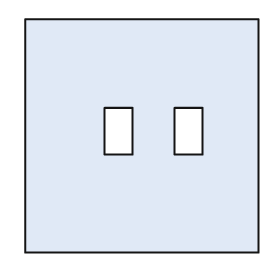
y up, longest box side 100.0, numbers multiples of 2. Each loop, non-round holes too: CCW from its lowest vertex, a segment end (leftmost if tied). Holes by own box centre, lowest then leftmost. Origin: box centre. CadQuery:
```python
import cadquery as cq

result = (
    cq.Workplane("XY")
    .moveTo(-50.0, -50.0)
    .lineTo(50.0, -50.0)
    .lineTo(50.0, 50.0)
    .lineTo(-50.0, 50.0)
    .close()
    .moveTo(-16.0, -8.0)
    .lineTo(-4.0, -8.0)
    .lineTo(-4.0, 12.0)
    .lineTo(-16.0, 12.0)
    .close()
    .moveTo(14.0, -8.0)
    .lineTo(26.0, -8.0)
    .lineTo(26.0, 12.0)
    .lineTo(14.0, 12.0)
    .close()
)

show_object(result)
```